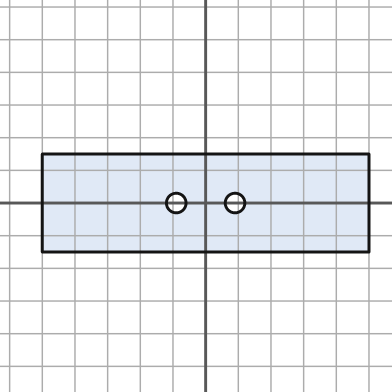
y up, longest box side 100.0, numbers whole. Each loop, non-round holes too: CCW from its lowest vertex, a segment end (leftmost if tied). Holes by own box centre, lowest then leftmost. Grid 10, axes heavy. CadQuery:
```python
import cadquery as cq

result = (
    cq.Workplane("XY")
    .moveTo(-50.0, -15.0)
    .lineTo(50.0, -15.0)
    .lineTo(50.0, 15.0)
    .lineTo(-50.0, 15.0)
    .close()
    .moveTo(-9.0, 0.0)
    .circle(3.0)
    .moveTo(9.0, 0.0)
    .circle(3.0)
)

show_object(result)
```